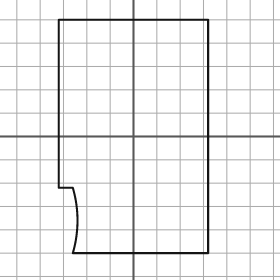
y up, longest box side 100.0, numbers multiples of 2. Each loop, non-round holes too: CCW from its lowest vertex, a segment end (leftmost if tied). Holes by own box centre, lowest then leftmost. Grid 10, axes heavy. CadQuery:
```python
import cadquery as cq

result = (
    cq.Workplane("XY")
    .moveTo(-26.0, -50.0)
    .lineTo(32.0, -50.0)
    .lineTo(32.0, 50.0)
    .lineTo(-32.0, 50.0)
    .lineTo(-32.0, -22.0)
    .lineTo(-26.0, -22.0)
    .threePointArc((-24.0, -36.0), (-26.0, -50.0))
    .close()
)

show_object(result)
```